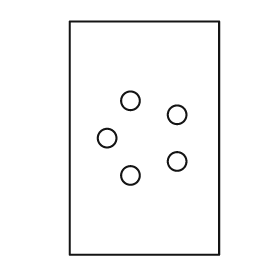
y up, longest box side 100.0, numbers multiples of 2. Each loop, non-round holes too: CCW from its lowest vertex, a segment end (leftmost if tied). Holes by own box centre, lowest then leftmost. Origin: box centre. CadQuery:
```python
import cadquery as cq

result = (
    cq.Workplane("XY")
    .moveTo(-32.0, -50.0)
    .lineTo(32.0, -50.0)
    .lineTo(32.0, 50.0)
    .lineTo(-32.0, 50.0)
    .close()
    .moveTo(-6.0, -16.0)
    .circle(4.0)
    .moveTo(14.0, -10.0)
    .circle(4.0)
    .moveTo(-16.0, 0.0)
    .circle(4.0)
    .moveTo(14.0, 10.0)
    .circle(4.0)
    .moveTo(-6.0, 16.0)
    .circle(4.0)
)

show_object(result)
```